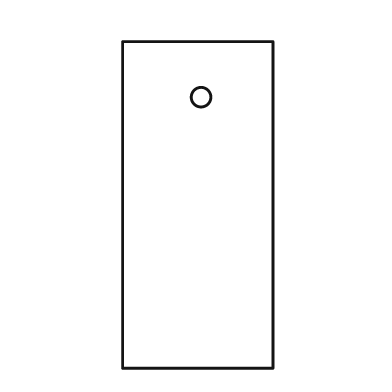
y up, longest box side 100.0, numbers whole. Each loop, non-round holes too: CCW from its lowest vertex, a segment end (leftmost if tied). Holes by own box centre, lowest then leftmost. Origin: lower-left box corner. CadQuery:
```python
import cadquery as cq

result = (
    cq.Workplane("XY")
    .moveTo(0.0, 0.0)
    .lineTo(46.0, 0.0)
    .lineTo(46.0, 100.0)
    .lineTo(0.0, 100.0)
    .close()
    .moveTo(24.0, 83.0)
    .circle(3.0)
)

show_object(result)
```